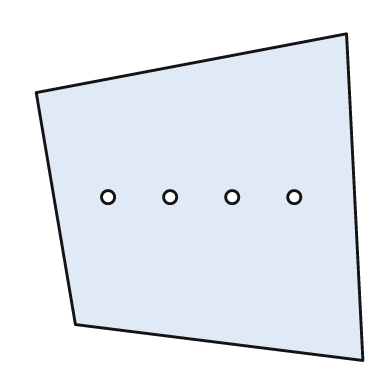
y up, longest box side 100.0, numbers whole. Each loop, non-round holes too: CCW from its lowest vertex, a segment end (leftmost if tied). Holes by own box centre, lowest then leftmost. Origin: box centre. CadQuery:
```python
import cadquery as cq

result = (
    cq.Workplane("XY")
    .moveTo(50.0, -50.0)
    .lineTo(45.0, 50.0)
    .lineTo(-50.0, 32.0)
    .lineTo(-38.0, -39.0)
    .close()
    .moveTo(-28.0, 0.0)
    .circle(2.0)
    .moveTo(-9.0, 0.0)
    .circle(2.0)
    .moveTo(10.0, 0.0)
    .circle(2.0)
    .moveTo(29.0, 0.0)
    .circle(2.0)
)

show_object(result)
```